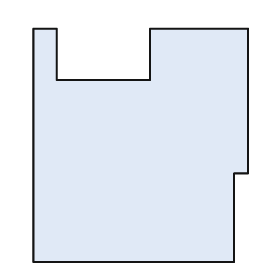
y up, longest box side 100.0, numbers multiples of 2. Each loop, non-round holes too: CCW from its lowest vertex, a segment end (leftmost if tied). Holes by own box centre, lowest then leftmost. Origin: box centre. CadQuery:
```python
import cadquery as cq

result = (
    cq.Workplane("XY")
    .moveTo(-46.0, -50.0)
    .lineTo(40.0, -50.0)
    .lineTo(40.0, -12.0)
    .lineTo(46.0, -12.0)
    .lineTo(46.0, 50.0)
    .lineTo(4.0, 50.0)
    .lineTo(4.0, 28.0)
    .lineTo(-36.0, 28.0)
    .lineTo(-36.0, 50.0)
    .lineTo(-46.0, 50.0)
    .close()
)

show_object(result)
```